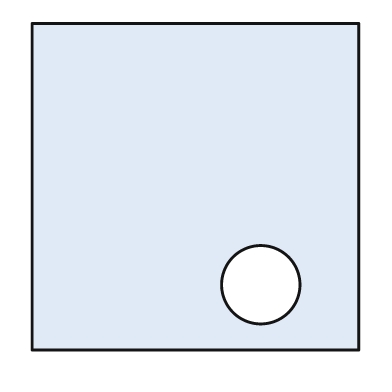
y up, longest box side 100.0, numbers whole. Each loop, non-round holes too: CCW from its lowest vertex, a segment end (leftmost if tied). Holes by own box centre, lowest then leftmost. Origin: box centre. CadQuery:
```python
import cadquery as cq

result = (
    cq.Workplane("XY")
    .moveTo(-50.0, -50.0)
    .lineTo(50.0, -50.0)
    .lineTo(50.0, 50.0)
    .lineTo(-50.0, 50.0)
    .close()
    .moveTo(20.0, -30.0)
    .circle(12.0)
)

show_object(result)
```